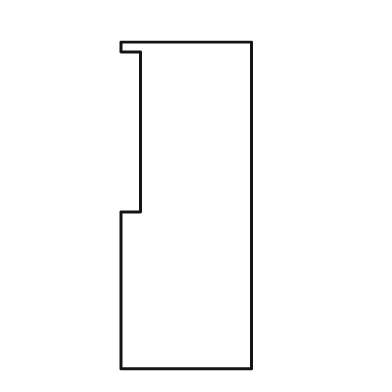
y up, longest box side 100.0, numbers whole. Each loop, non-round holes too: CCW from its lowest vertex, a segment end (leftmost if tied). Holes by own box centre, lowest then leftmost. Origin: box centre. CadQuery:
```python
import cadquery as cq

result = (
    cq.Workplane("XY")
    .moveTo(-20.0, -50.0)
    .lineTo(20.0, -50.0)
    .lineTo(20.0, 50.0)
    .lineTo(-20.0, 50.0)
    .lineTo(-20.0, 47.0)
    .lineTo(-14.0, 47.0)
    .lineTo(-14.0, -2.0)
    .lineTo(-20.0, -2.0)
    .close()
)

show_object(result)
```